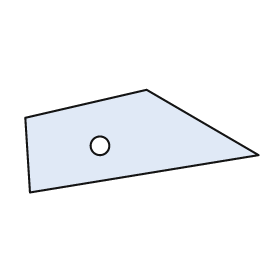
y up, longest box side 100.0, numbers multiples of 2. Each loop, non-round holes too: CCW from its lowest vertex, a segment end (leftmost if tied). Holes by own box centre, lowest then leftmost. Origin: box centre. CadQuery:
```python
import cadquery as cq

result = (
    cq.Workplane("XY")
    .moveTo(-48.0, -22.0)
    .lineTo(50.0, -6.0)
    .lineTo(2.0, 22.0)
    .lineTo(-50.0, 10.0)
    .close()
    .moveTo(-18.0, -2.0)
    .circle(4.0)
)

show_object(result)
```